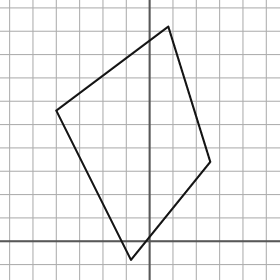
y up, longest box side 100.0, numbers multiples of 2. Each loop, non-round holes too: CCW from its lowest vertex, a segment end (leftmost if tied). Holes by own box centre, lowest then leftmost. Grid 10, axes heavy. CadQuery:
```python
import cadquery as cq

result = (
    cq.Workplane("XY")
    .moveTo(-8.0, -8.0)
    .lineTo(26.0, 34.0)
    .lineTo(8.0, 92.0)
    .lineTo(-40.0, 56.0)
    .close()
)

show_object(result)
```